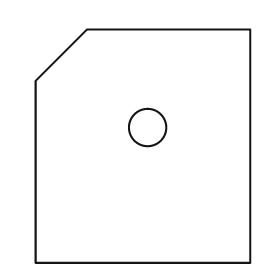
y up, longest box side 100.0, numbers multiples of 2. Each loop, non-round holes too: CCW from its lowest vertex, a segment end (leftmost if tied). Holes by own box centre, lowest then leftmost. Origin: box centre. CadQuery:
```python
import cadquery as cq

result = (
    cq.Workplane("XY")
    .moveTo(-46.0, -50.0)
    .lineTo(46.0, -50.0)
    .lineTo(46.0, 50.0)
    .lineTo(-24.0, 50.0)
    .lineTo(-46.0, 28.0)
    .close()
    .moveTo(2.0, 8.0)
    .circle(8.0)
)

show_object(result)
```